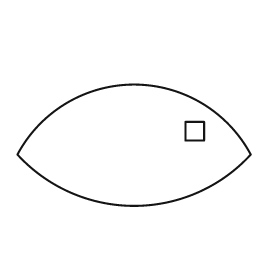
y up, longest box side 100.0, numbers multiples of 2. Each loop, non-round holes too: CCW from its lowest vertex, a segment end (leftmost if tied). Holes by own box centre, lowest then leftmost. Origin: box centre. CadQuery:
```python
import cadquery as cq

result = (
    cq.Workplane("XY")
    .moveTo(-50.0, -4.0)
    .threePointArc((0.0, -26.0), (50.0, -4.0))
    .threePointArc((0.0, 26.0), (-50.0, -4.0))
    .close()
    .moveTo(22.0, 2.0)
    .lineTo(30.0, 2.0)
    .lineTo(30.0, 10.0)
    .lineTo(22.0, 10.0)
    .close()
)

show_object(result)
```